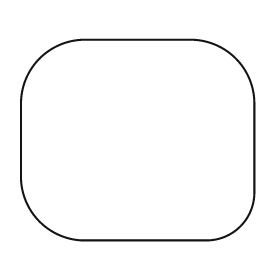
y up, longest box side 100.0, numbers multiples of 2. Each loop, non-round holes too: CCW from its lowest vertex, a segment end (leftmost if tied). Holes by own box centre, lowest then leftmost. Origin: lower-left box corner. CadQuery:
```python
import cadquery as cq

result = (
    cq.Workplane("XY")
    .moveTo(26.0, 0.0)
    .lineTo(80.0, 0.0)
    .threePointArc((94.0, 6.0), (100.0, 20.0))
    .lineTo(100.0, 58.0)
    .threePointArc((92.0, 78.0), (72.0, 86.0))
    .lineTo(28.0, 86.0)
    .threePointArc((8.0, 78.0), (0.0, 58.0))
    .lineTo(0.0, 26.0)
    .threePointArc((8.0, 8.0), (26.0, 0.0))
    .close()
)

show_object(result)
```